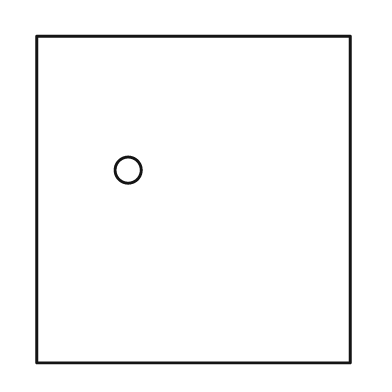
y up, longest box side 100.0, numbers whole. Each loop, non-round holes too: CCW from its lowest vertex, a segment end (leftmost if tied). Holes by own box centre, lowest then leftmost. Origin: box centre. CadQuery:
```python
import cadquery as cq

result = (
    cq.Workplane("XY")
    .moveTo(-48.0, -50.0)
    .lineTo(48.0, -50.0)
    .lineTo(48.0, 50.0)
    .lineTo(-48.0, 50.0)
    .close()
    .moveTo(-20.0, 9.0)
    .circle(4.0)
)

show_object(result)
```